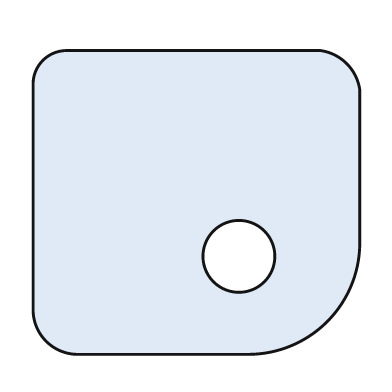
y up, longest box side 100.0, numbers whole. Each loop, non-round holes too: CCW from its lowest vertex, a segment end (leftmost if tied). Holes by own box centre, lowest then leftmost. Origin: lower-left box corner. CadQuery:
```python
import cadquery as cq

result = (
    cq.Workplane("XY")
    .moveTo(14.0, 0.0)
    .lineTo(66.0, 0.0)
    .threePointArc((90.0, 10.0), (100.0, 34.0))
    .lineTo(100.0, 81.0)
    .threePointArc((96.0, 89.0), (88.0, 93.0))
    .lineTo(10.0, 93.0)
    .threePointArc((3.0, 90.0), (0.0, 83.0))
    .lineTo(0.0, 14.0)
    .threePointArc((4.0, 4.0), (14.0, 0.0))
    .close()
    .moveTo(63.0, 30.0)
    .circle(11.0)
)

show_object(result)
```